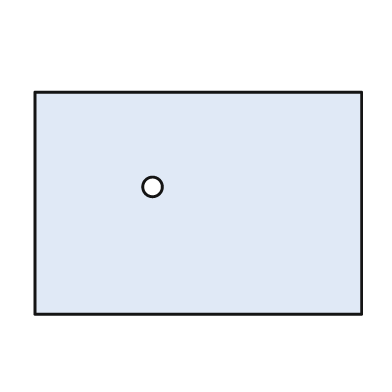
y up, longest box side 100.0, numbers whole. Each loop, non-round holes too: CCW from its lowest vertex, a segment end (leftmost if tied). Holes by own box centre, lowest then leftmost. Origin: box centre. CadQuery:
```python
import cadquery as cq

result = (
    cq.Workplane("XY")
    .moveTo(-50.0, -34.0)
    .lineTo(50.0, -34.0)
    .lineTo(50.0, 34.0)
    .lineTo(-50.0, 34.0)
    .close()
    .moveTo(-14.0, 5.0)
    .circle(3.0)
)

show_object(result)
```